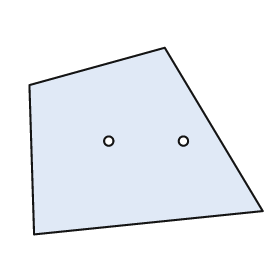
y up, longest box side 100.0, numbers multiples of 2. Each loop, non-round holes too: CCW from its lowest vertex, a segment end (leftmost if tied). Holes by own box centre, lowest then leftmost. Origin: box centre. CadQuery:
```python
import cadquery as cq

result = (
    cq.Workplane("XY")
    .moveTo(-48.0, -40.0)
    .lineTo(50.0, -30.0)
    .lineTo(8.0, 40.0)
    .lineTo(-50.0, 24.0)
    .close()
    .moveTo(-16.0, 0.0)
    .circle(2.0)
    .moveTo(16.0, 0.0)
    .circle(2.0)
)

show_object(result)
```